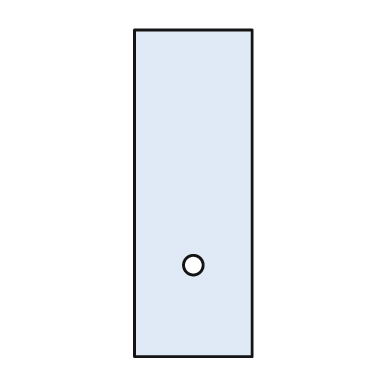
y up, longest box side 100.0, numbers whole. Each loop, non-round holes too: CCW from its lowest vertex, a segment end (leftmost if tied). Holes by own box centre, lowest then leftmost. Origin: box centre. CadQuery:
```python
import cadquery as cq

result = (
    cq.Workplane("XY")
    .moveTo(-18.0, -50.0)
    .lineTo(18.0, -50.0)
    .lineTo(18.0, 50.0)
    .lineTo(-18.0, 50.0)
    .close()
    .moveTo(0.0, -22.0)
    .circle(3.0)
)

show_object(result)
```